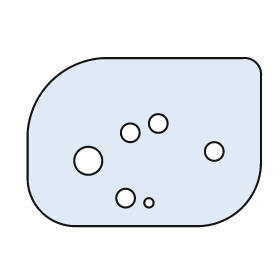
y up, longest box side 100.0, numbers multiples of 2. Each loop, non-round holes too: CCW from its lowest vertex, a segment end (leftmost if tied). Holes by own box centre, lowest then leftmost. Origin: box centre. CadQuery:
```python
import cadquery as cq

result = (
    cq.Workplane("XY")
    .moveTo(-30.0, -36.0)
    .lineTo(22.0, -36.0)
    .threePointArc((42.0, -28.0), (50.0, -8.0))
    .lineTo(50.0, 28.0)
    .threePointArc((48.0, 34.0), (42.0, 36.0))
    .lineTo(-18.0, 36.0)
    .threePointArc((-40.0, 26.0), (-50.0, 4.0))
    .lineTo(-50.0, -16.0)
    .threePointArc((-44.0, -30.0), (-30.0, -36.0))
    .close()
    .moveTo(2.0, -26.0)
    .circle(2.0)
    .moveTo(-8.0, -24.0)
    .circle(4.0)
    .moveTo(-24.0, -8.0)
    .circle(6.0)
    .moveTo(30.0, -4.0)
    .circle(4.0)
    .moveTo(-6.0, 4.0)
    .circle(4.0)
    .moveTo(6.0, 8.0)
    .circle(4.0)
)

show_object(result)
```